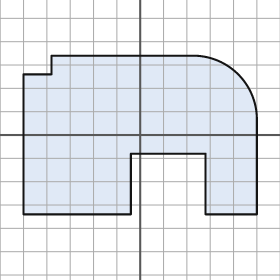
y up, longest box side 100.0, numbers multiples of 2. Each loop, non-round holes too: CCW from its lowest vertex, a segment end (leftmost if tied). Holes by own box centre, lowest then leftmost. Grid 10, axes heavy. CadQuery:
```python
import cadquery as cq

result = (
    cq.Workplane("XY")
    .moveTo(-50.0, -34.0)
    .lineTo(-4.0, -34.0)
    .lineTo(-4.0, -8.0)
    .lineTo(28.0, -8.0)
    .lineTo(28.0, -34.0)
    .lineTo(50.0, -34.0)
    .lineTo(50.0, 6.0)
    .threePointArc((42.0, 26.0), (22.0, 34.0))
    .lineTo(-38.0, 34.0)
    .lineTo(-38.0, 26.0)
    .lineTo(-50.0, 26.0)
    .close()
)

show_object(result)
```